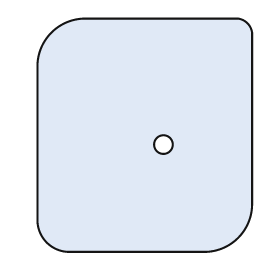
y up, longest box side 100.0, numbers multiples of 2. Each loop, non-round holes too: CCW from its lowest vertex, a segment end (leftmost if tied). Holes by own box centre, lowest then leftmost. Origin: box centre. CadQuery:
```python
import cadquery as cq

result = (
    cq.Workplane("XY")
    .moveTo(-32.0, -50.0)
    .lineTo(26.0, -50.0)
    .threePointArc((40.0, -44.0), (46.0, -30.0))
    .lineTo(46.0, 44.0)
    .threePointArc((44.0, 48.0), (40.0, 50.0))
    .lineTo(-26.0, 50.0)
    .threePointArc((-40.0, 44.0), (-46.0, 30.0))
    .lineTo(-46.0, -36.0)
    .threePointArc((-42.0, -46.0), (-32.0, -50.0))
    .close()
    .moveTo(8.0, -4.0)
    .circle(4.0)
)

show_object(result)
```